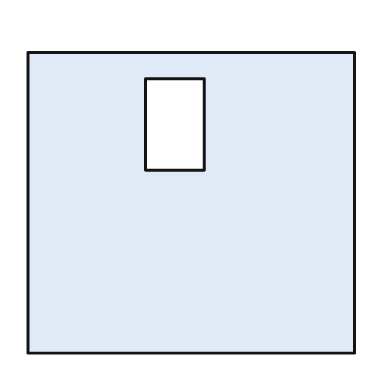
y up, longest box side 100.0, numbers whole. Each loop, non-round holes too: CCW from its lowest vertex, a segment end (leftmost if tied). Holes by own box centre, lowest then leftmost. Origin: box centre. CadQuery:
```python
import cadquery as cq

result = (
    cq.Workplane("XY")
    .moveTo(-50.0, -46.0)
    .lineTo(50.0, -46.0)
    .lineTo(50.0, 46.0)
    .lineTo(-50.0, 46.0)
    .close()
    .moveTo(-14.0, 10.0)
    .lineTo(4.0, 10.0)
    .lineTo(4.0, 38.0)
    .lineTo(-14.0, 38.0)
    .close()
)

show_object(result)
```